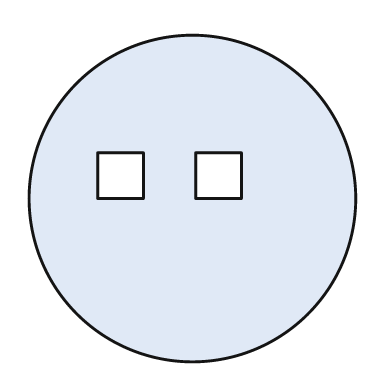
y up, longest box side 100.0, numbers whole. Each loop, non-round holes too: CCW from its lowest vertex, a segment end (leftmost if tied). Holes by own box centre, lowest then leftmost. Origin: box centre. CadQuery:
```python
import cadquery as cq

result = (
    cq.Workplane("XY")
    .moveTo(0.0, 0.0)
    .circle(50.0)
    .moveTo(-29.0, 0.0)
    .lineTo(-15.0, 0.0)
    .lineTo(-15.0, 14.0)
    .lineTo(-29.0, 14.0)
    .close()
    .moveTo(1.0, 0.0)
    .lineTo(15.0, 0.0)
    .lineTo(15.0, 14.0)
    .lineTo(1.0, 14.0)
    .close()
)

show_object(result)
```